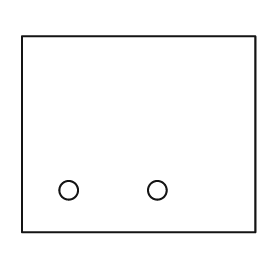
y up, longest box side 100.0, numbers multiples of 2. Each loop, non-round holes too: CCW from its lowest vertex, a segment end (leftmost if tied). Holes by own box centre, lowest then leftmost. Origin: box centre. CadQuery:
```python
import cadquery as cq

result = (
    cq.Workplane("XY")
    .moveTo(-50.0, -42.0)
    .lineTo(50.0, -42.0)
    .lineTo(50.0, 42.0)
    .lineTo(-50.0, 42.0)
    .close()
    .moveTo(-30.0, -24.0)
    .circle(4.0)
    .moveTo(8.0, -24.0)
    .circle(4.0)
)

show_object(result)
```